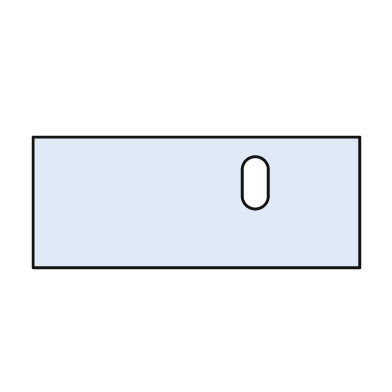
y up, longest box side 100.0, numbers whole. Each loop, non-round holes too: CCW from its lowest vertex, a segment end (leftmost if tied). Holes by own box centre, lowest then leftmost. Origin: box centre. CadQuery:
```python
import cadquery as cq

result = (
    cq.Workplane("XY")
    .moveTo(-50.0, -20.0)
    .lineTo(50.0, -20.0)
    .lineTo(50.0, 20.0)
    .lineTo(-50.0, 20.0)
    .close()
    .moveTo(14.0, 2.0)
    .threePointArc((18.0, -2.0), (22.0, 2.0))
    .lineTo(22.0, 10.0)
    .threePointArc((18.0, 14.0), (14.0, 10.0))
    .close()
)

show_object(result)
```